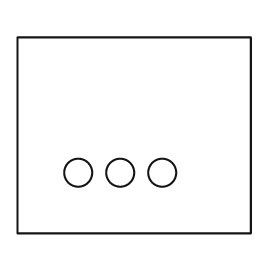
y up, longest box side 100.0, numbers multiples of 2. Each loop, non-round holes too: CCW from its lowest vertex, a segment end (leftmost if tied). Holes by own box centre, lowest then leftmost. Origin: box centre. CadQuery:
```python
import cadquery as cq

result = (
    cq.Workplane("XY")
    .moveTo(-50.0, -42.0)
    .lineTo(50.0, -42.0)
    .lineTo(50.0, 42.0)
    .lineTo(-50.0, 42.0)
    .close()
    .moveTo(-24.0, -16.0)
    .circle(6.0)
    .moveTo(-6.0, -16.0)
    .circle(6.0)
    .moveTo(12.0, -16.0)
    .circle(6.0)
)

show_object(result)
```